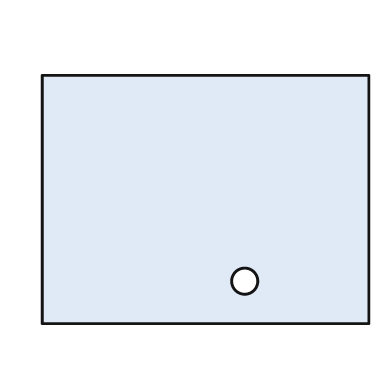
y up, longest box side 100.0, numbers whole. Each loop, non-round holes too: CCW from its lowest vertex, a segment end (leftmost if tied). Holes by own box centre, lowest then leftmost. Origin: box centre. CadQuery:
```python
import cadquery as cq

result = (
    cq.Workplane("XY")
    .moveTo(-50.0, -38.0)
    .lineTo(50.0, -38.0)
    .lineTo(50.0, 38.0)
    .lineTo(-50.0, 38.0)
    .close()
    .moveTo(12.0, -25.0)
    .circle(4.0)
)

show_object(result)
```